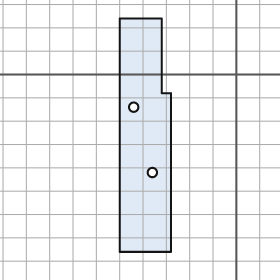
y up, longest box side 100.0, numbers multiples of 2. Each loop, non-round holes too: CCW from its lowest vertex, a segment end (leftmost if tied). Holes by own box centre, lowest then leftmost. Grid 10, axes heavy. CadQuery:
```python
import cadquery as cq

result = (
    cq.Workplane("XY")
    .moveTo(-50.0, -76.0)
    .lineTo(-28.0, -76.0)
    .lineTo(-28.0, -8.0)
    .lineTo(-32.0, -8.0)
    .lineTo(-32.0, 24.0)
    .lineTo(-50.0, 24.0)
    .close()
    .moveTo(-36.0, -42.0)
    .circle(2.0)
    .moveTo(-44.0, -14.0)
    .circle(2.0)
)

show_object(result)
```